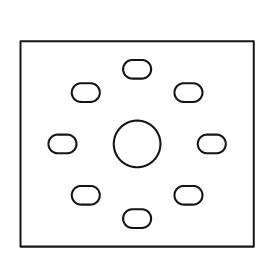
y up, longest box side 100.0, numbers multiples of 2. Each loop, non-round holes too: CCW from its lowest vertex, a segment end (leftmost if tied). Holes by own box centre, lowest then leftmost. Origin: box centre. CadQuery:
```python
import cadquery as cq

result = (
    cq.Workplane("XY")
    .moveTo(-50.0, -44.0)
    .lineTo(50.0, -44.0)
    .lineTo(50.0, 44.0)
    .lineTo(-50.0, 44.0)
    .close()
    .moveTo(-2.0, -36.0)
    .lineTo(2.0, -36.0)
    .threePointArc((6.0, -32.0), (2.0, -28.0))
    .lineTo(-2.0, -28.0)
    .threePointArc((-6.0, -32.0), (-2.0, -36.0))
    .close()
    .moveTo(-24.0, -26.0)
    .lineTo(-20.0, -26.0)
    .threePointArc((-16.0, -22.0), (-20.0, -18.0))
    .lineTo(-24.0, -18.0)
    .threePointArc((-28.0, -22.0), (-24.0, -26.0))
    .close()
    .moveTo(20.0, -26.0)
    .lineTo(24.0, -26.0)
    .threePointArc((28.0, -22.0), (24.0, -18.0))
    .lineTo(20.0, -18.0)
    .threePointArc((16.0, -22.0), (20.0, -26.0))
    .close()
    .moveTo(-34.0, -4.0)
    .lineTo(-30.0, -4.0)
    .threePointArc((-26.0, 0.0), (-30.0, 4.0))
    .lineTo(-34.0, 4.0)
    .threePointArc((-38.0, 0.0), (-34.0, -4.0))
    .close()
    .moveTo(0.0, 0.0)
    .circle(10.0)
    .moveTo(30.0, -4.0)
    .lineTo(34.0, -4.0)
    .threePointArc((38.0, 0.0), (34.0, 4.0))
    .lineTo(30.0, 4.0)
    .threePointArc((26.0, 0.0), (30.0, -4.0))
    .close()
    .moveTo(-24.0, 18.0)
    .lineTo(-20.0, 18.0)
    .threePointArc((-16.0, 22.0), (-20.0, 26.0))
    .lineTo(-24.0, 26.0)
    .threePointArc((-28.0, 22.0), (-24.0, 18.0))
    .close()
    .moveTo(20.0, 18.0)
    .lineTo(24.0, 18.0)
    .threePointArc((28.0, 22.0), (24.0, 26.0))
    .lineTo(20.0, 26.0)
    .threePointArc((16.0, 22.0), (20.0, 18.0))
    .close()
    .moveTo(-2.0, 28.0)
    .lineTo(2.0, 28.0)
    .threePointArc((6.0, 32.0), (2.0, 36.0))
    .lineTo(-2.0, 36.0)
    .threePointArc((-6.0, 32.0), (-2.0, 28.0))
    .close()
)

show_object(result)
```